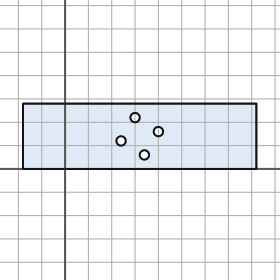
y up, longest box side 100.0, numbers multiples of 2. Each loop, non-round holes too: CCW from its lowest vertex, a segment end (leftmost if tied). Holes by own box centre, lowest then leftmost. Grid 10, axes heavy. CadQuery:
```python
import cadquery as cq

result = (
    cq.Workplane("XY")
    .moveTo(-18.0, 0.0)
    .lineTo(82.0, 0.0)
    .lineTo(82.0, 28.0)
    .lineTo(-18.0, 28.0)
    .close()
    .moveTo(34.0, 6.0)
    .circle(2.0)
    .moveTo(24.0, 12.0)
    .circle(2.0)
    .moveTo(40.0, 16.0)
    .circle(2.0)
    .moveTo(30.0, 22.0)
    .circle(2.0)
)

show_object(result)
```